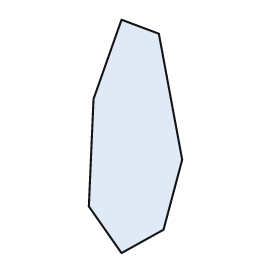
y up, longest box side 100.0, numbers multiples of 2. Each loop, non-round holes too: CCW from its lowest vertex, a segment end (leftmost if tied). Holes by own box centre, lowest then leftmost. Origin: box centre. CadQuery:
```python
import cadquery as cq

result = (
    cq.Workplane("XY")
    .moveTo(-6.0, -50.0)
    .lineTo(12.0, -40.0)
    .lineTo(20.0, -10.0)
    .lineTo(10.0, 44.0)
    .lineTo(-6.0, 50.0)
    .lineTo(-18.0, 16.0)
    .lineTo(-20.0, -30.0)
    .close()
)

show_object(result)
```